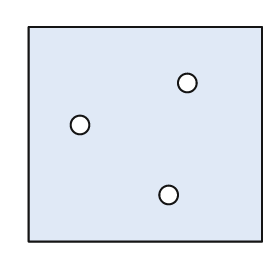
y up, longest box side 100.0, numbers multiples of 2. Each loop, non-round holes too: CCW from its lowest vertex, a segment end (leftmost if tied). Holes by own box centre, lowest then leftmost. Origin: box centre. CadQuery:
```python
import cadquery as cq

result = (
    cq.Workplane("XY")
    .moveTo(-50.0, -46.0)
    .lineTo(50.0, -46.0)
    .lineTo(50.0, 46.0)
    .lineTo(-50.0, 46.0)
    .close()
    .moveTo(10.0, -26.0)
    .circle(4.0)
    .moveTo(-28.0, 4.0)
    .circle(4.0)
    .moveTo(18.0, 22.0)
    .circle(4.0)
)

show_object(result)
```